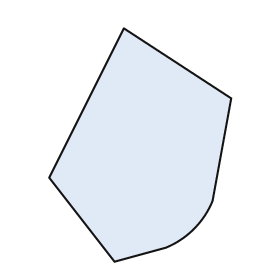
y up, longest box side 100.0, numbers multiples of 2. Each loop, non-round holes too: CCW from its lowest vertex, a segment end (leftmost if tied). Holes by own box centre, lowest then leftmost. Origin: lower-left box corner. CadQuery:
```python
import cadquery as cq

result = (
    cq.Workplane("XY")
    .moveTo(28.0, 0.0)
    .lineTo(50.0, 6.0)
    .threePointArc((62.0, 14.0), (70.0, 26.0))
    .lineTo(78.0, 70.0)
    .lineTo(32.0, 100.0)
    .lineTo(0.0, 36.0)
    .close()
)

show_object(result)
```